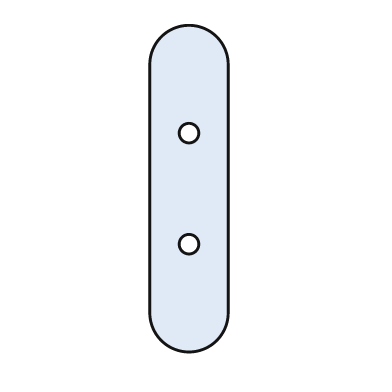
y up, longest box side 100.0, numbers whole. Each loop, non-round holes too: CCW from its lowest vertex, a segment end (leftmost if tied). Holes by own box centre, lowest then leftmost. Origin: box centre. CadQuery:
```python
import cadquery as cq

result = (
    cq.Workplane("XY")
    .moveTo(-12.0, -38.0)
    .threePointArc((0.0, -50.0), (12.0, -38.0))
    .lineTo(12.0, 38.0)
    .threePointArc((0.0, 50.0), (-12.0, 38.0))
    .close()
    .moveTo(0.0, -17.0)
    .circle(3.0)
    .moveTo(0.0, 17.0)
    .circle(3.0)
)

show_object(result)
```